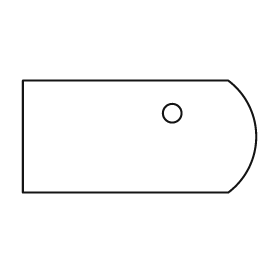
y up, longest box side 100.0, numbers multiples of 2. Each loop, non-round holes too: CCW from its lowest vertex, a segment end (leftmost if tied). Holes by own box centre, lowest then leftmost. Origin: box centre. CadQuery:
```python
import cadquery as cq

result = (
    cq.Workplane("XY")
    .moveTo(-50.0, -24.0)
    .lineTo(38.0, -24.0)
    .threePointArc((50.0, 0.0), (38.0, 24.0))
    .lineTo(-50.0, 24.0)
    .close()
    .moveTo(14.0, 10.0)
    .circle(4.0)
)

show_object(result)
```